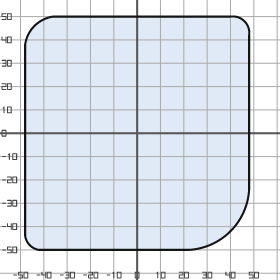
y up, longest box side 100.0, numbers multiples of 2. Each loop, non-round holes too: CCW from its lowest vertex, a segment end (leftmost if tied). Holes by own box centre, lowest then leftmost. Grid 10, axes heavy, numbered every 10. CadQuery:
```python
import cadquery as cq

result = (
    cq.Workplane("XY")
    .moveTo(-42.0, -50.0)
    .lineTo(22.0, -50.0)
    .threePointArc((40.0, -42.0), (48.0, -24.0))
    .lineTo(48.0, 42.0)
    .threePointArc((46.0, 48.0), (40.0, 50.0))
    .lineTo(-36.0, 50.0)
    .threePointArc((-44.0, 46.0), (-48.0, 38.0))
    .lineTo(-48.0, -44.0)
    .threePointArc((-46.0, -48.0), (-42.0, -50.0))
    .close()
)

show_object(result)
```